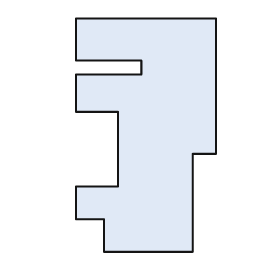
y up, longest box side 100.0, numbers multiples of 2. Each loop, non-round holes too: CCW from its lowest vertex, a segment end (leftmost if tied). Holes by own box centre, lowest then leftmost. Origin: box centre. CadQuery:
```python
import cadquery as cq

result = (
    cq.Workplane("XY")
    .moveTo(-18.0, -50.0)
    .lineTo(20.0, -50.0)
    .lineTo(20.0, -8.0)
    .lineTo(30.0, -8.0)
    .lineTo(30.0, 50.0)
    .lineTo(-30.0, 50.0)
    .lineTo(-30.0, 32.0)
    .lineTo(-2.0, 32.0)
    .lineTo(-2.0, 26.0)
    .lineTo(-30.0, 26.0)
    .lineTo(-30.0, 10.0)
    .lineTo(-12.0, 10.0)
    .lineTo(-12.0, -22.0)
    .lineTo(-30.0, -22.0)
    .lineTo(-30.0, -36.0)
    .lineTo(-18.0, -36.0)
    .close()
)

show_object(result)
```